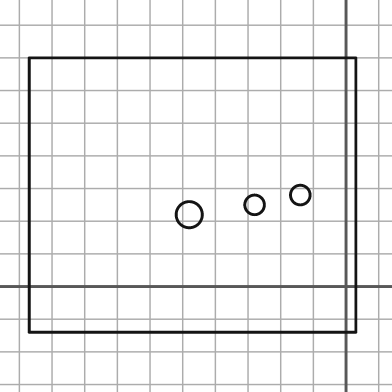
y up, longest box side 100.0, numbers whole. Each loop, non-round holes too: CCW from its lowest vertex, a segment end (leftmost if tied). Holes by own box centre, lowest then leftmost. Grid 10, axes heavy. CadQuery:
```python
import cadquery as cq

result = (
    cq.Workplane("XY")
    .moveTo(-97.0, -14.0)
    .lineTo(3.0, -14.0)
    .lineTo(3.0, 70.0)
    .lineTo(-97.0, 70.0)
    .close()
    .moveTo(-48.0, 22.0)
    .circle(4.0)
    .moveTo(-28.0, 25.0)
    .circle(3.0)
    .moveTo(-14.0, 28.0)
    .circle(3.0)
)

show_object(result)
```